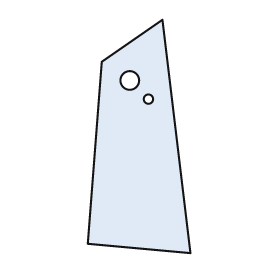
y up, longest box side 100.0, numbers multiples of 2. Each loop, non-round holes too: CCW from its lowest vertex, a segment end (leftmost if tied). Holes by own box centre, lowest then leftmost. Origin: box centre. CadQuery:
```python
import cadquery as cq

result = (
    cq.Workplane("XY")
    .moveTo(22.0, -50.0)
    .lineTo(10.0, 50.0)
    .lineTo(-16.0, 32.0)
    .lineTo(-22.0, -46.0)
    .close()
    .moveTo(4.0, 16.0)
    .circle(2.0)
    .moveTo(-4.0, 24.0)
    .circle(4.0)
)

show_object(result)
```